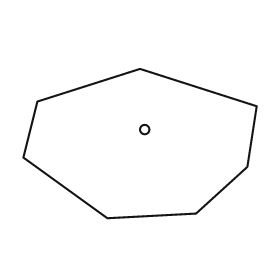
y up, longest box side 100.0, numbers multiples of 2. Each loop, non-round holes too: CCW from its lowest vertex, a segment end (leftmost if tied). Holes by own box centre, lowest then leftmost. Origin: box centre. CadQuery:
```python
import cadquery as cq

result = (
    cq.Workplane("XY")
    .moveTo(-14.0, -32.0)
    .lineTo(24.0, -30.0)
    .lineTo(46.0, -10.0)
    .lineTo(50.0, 16.0)
    .lineTo(0.0, 32.0)
    .lineTo(-44.0, 18.0)
    .lineTo(-50.0, -6.0)
    .close()
    .moveTo(2.0, 6.0)
    .circle(2.0)
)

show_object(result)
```